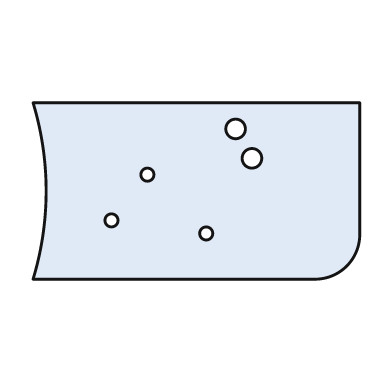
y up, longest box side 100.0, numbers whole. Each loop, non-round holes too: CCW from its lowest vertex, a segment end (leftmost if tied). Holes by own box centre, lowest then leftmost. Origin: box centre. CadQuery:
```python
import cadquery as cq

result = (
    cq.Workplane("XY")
    .moveTo(-50.0, -27.0)
    .lineTo(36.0, -27.0)
    .threePointArc((46.0, -23.0), (50.0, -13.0))
    .lineTo(50.0, 27.0)
    .lineTo(-50.0, 27.0)
    .threePointArc((-46.0, 0.0), (-50.0, -27.0))
    .close()
    .moveTo(3.0, -13.0)
    .circle(2.0)
    .moveTo(-26.0, -9.0)
    .circle(2.0)
    .moveTo(-15.0, 5.0)
    .circle(2.0)
    .moveTo(17.0, 10.0)
    .circle(3.0)
    .moveTo(12.0, 19.0)
    .circle(3.0)
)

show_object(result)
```